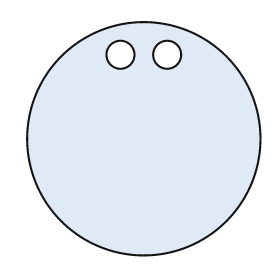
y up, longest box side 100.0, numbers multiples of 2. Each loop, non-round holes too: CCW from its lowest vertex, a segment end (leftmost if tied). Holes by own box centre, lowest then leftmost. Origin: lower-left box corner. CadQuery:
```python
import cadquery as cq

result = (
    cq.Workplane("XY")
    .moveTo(50.0, 50.0)
    .circle(50.0)
    .moveTo(40.0, 86.0)
    .circle(6.0)
    .moveTo(60.0, 86.0)
    .circle(6.0)
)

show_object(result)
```